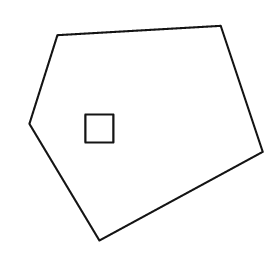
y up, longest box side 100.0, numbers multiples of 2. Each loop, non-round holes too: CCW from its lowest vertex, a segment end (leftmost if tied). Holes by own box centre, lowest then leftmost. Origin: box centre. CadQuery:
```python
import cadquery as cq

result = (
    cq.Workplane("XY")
    .moveTo(-20.0, -46.0)
    .lineTo(50.0, -8.0)
    .lineTo(32.0, 46.0)
    .lineTo(-38.0, 42.0)
    .lineTo(-50.0, 4.0)
    .close()
    .moveTo(-26.0, -4.0)
    .lineTo(-14.0, -4.0)
    .lineTo(-14.0, 8.0)
    .lineTo(-26.0, 8.0)
    .close()
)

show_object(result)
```